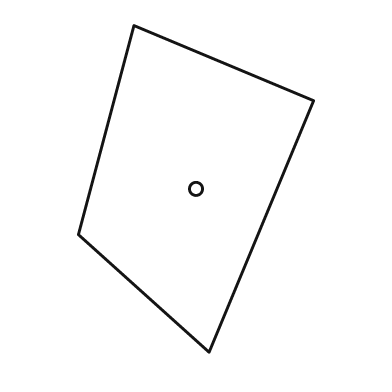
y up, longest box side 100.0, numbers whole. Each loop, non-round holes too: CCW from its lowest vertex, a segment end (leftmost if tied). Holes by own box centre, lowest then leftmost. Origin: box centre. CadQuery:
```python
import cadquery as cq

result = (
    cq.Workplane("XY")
    .moveTo(4.0, -50.0)
    .lineTo(36.0, 27.0)
    .lineTo(-19.0, 50.0)
    .lineTo(-36.0, -14.0)
    .close()
    .moveTo(0.0, 0.0)
    .circle(2.0)
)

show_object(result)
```